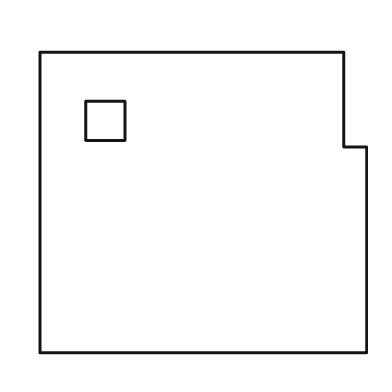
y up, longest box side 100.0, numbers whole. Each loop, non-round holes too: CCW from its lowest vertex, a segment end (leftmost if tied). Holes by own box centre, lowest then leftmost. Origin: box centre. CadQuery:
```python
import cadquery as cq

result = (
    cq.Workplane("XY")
    .moveTo(-50.0, -46.0)
    .lineTo(50.0, -46.0)
    .lineTo(50.0, 17.0)
    .lineTo(43.0, 17.0)
    .lineTo(43.0, 46.0)
    .lineTo(-50.0, 46.0)
    .close()
    .moveTo(-36.0, 19.0)
    .lineTo(-24.0, 19.0)
    .lineTo(-24.0, 31.0)
    .lineTo(-36.0, 31.0)
    .close()
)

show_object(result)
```